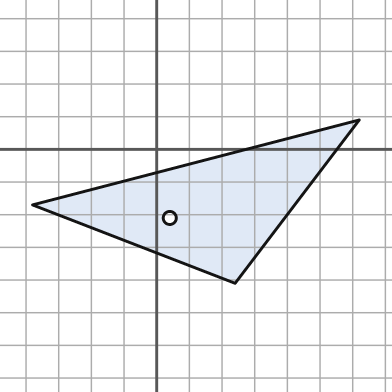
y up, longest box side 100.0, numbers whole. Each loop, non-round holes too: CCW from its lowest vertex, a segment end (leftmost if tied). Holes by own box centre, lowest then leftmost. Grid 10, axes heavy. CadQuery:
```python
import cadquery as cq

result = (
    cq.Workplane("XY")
    .moveTo(24.0, -41.0)
    .lineTo(62.0, 9.0)
    .lineTo(-38.0, -17.0)
    .close()
    .moveTo(4.0, -21.0)
    .circle(2.0)
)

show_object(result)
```